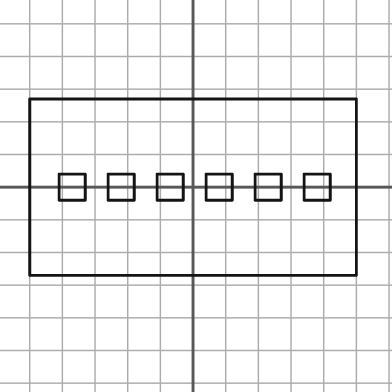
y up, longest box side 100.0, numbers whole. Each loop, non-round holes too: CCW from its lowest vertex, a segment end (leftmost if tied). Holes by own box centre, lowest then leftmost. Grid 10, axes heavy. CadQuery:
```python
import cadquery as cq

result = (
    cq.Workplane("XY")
    .moveTo(-50.0, -27.0)
    .lineTo(50.0, -27.0)
    .lineTo(50.0, 27.0)
    .lineTo(-50.0, 27.0)
    .close()
    .moveTo(-41.0, -4.0)
    .lineTo(-33.0, -4.0)
    .lineTo(-33.0, 4.0)
    .lineTo(-41.0, 4.0)
    .close()
    .moveTo(-26.0, -4.0)
    .lineTo(-18.0, -4.0)
    .lineTo(-18.0, 4.0)
    .lineTo(-26.0, 4.0)
    .close()
    .moveTo(-11.0, -4.0)
    .lineTo(-3.0, -4.0)
    .lineTo(-3.0, 4.0)
    .lineTo(-11.0, 4.0)
    .close()
    .moveTo(4.0, -4.0)
    .lineTo(12.0, -4.0)
    .lineTo(12.0, 4.0)
    .lineTo(4.0, 4.0)
    .close()
    .moveTo(19.0, -4.0)
    .lineTo(27.0, -4.0)
    .lineTo(27.0, 4.0)
    .lineTo(19.0, 4.0)
    .close()
    .moveTo(34.0, -4.0)
    .lineTo(42.0, -4.0)
    .lineTo(42.0, 4.0)
    .lineTo(34.0, 4.0)
    .close()
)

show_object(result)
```